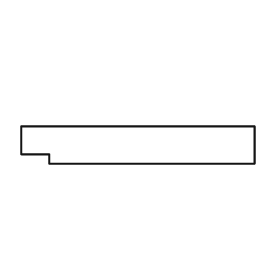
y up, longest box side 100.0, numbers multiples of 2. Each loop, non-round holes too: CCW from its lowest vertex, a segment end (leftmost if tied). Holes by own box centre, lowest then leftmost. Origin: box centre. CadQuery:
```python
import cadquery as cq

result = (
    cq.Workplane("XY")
    .moveTo(-38.0, -8.0)
    .lineTo(50.0, -8.0)
    .lineTo(50.0, 8.0)
    .lineTo(-50.0, 8.0)
    .lineTo(-50.0, -4.0)
    .lineTo(-38.0, -4.0)
    .close()
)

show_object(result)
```